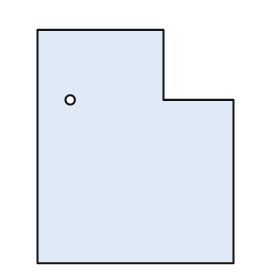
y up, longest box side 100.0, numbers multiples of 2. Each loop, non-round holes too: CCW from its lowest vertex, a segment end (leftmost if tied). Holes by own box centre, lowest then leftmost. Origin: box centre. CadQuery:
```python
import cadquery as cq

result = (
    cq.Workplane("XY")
    .moveTo(-42.0, -50.0)
    .lineTo(42.0, -50.0)
    .lineTo(42.0, 20.0)
    .lineTo(12.0, 20.0)
    .lineTo(12.0, 50.0)
    .lineTo(-42.0, 50.0)
    .close()
    .moveTo(-28.0, 20.0)
    .circle(2.0)
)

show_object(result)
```